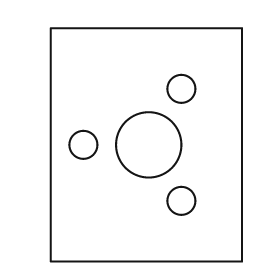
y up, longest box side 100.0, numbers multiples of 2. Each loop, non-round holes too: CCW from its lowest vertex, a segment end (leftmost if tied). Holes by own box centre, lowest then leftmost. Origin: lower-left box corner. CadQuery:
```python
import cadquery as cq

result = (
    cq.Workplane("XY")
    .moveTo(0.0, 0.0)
    .lineTo(82.0, 0.0)
    .lineTo(82.0, 100.0)
    .lineTo(0.0, 100.0)
    .close()
    .moveTo(56.0, 26.0)
    .circle(6.0)
    .moveTo(14.0, 50.0)
    .circle(6.0)
    .moveTo(42.0, 50.0)
    .circle(14.0)
    .moveTo(56.0, 74.0)
    .circle(6.0)
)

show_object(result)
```